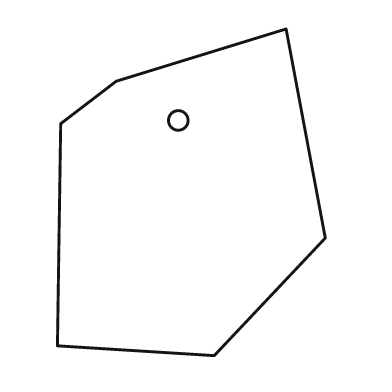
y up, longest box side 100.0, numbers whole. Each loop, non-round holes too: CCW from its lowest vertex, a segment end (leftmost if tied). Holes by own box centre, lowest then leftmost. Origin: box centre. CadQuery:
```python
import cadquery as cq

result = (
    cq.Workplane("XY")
    .moveTo(7.0, -50.0)
    .lineTo(41.0, -14.0)
    .lineTo(29.0, 50.0)
    .lineTo(-23.0, 34.0)
    .lineTo(-40.0, 21.0)
    .lineTo(-41.0, -47.0)
    .close()
    .moveTo(-4.0, 22.0)
    .circle(3.0)
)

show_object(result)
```